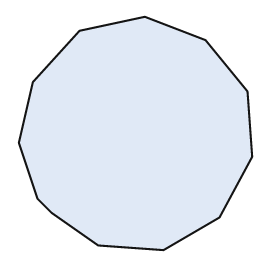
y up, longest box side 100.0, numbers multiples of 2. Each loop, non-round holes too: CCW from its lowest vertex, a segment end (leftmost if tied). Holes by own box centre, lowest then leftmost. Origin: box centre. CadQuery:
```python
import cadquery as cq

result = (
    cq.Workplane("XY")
    .moveTo(12.0, -50.0)
    .lineTo(36.0, -36.0)
    .lineTo(50.0, -10.0)
    .lineTo(48.0, 18.0)
    .lineTo(30.0, 40.0)
    .lineTo(4.0, 50.0)
    .lineTo(-24.0, 44.0)
    .lineTo(-44.0, 22.0)
    .lineTo(-50.0, -4.0)
    .lineTo(-42.0, -28.0)
    .lineTo(-36.0, -34.0)
    .lineTo(-16.0, -48.0)
    .close()
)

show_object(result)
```